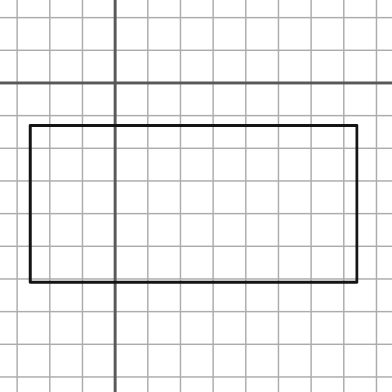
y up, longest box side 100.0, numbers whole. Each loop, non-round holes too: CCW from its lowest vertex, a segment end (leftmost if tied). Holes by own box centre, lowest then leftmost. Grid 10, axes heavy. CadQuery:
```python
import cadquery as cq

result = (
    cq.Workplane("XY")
    .moveTo(-26.0, -61.0)
    .lineTo(74.0, -61.0)
    .lineTo(74.0, -13.0)
    .lineTo(-26.0, -13.0)
    .close()
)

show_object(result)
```